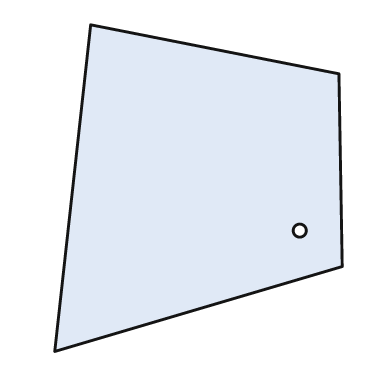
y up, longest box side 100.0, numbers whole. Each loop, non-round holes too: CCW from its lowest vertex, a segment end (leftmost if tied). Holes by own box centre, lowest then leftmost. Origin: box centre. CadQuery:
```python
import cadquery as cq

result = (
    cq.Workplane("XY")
    .moveTo(-44.0, -50.0)
    .lineTo(44.0, -24.0)
    .lineTo(43.0, 35.0)
    .lineTo(-33.0, 50.0)
    .close()
    .moveTo(31.0, -13.0)
    .circle(2.0)
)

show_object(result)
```